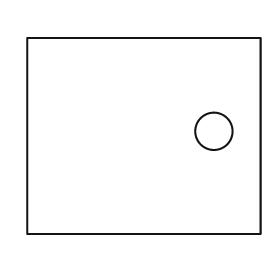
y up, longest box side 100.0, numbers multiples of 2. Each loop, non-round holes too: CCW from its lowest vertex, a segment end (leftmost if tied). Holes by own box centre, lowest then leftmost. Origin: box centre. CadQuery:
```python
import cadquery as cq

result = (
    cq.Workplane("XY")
    .moveTo(-50.0, -42.0)
    .lineTo(50.0, -42.0)
    .lineTo(50.0, 42.0)
    .lineTo(-50.0, 42.0)
    .close()
    .moveTo(30.0, 2.0)
    .circle(8.0)
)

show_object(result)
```